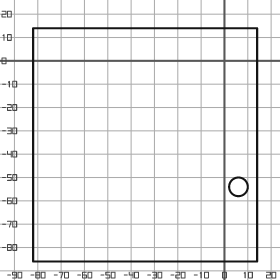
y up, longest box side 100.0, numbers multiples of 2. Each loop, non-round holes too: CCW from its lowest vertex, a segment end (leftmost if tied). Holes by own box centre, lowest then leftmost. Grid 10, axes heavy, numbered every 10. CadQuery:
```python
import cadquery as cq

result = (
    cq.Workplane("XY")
    .moveTo(-82.0, -86.0)
    .lineTo(14.0, -86.0)
    .lineTo(14.0, 14.0)
    .lineTo(-82.0, 14.0)
    .close()
    .moveTo(6.0, -54.0)
    .circle(4.0)
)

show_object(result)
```